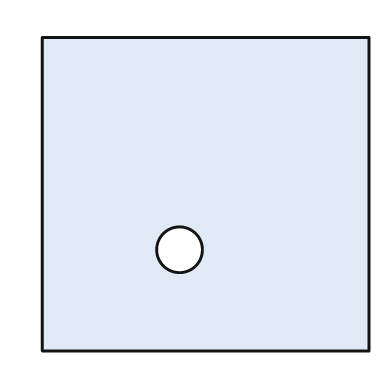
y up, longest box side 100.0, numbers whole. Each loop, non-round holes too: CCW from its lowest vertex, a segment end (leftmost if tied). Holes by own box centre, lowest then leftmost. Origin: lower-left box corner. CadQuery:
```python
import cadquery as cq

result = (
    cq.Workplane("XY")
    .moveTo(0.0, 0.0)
    .lineTo(100.0, 0.0)
    .lineTo(100.0, 96.0)
    .lineTo(0.0, 96.0)
    .close()
    .moveTo(42.0, 31.0)
    .circle(7.0)
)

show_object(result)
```